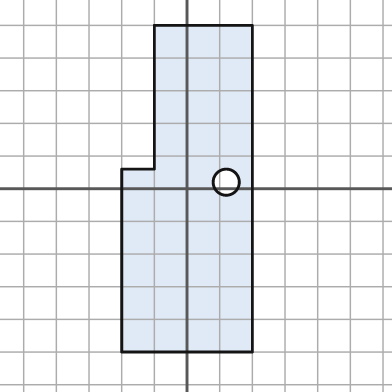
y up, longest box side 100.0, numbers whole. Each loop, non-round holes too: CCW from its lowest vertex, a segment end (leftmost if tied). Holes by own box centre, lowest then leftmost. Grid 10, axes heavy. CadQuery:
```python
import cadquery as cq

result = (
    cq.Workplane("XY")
    .moveTo(-20.0, -50.0)
    .lineTo(20.0, -50.0)
    .lineTo(20.0, 50.0)
    .lineTo(-10.0, 50.0)
    .lineTo(-10.0, 6.0)
    .lineTo(-20.0, 6.0)
    .close()
    .moveTo(12.0, 2.0)
    .circle(4.0)
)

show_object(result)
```